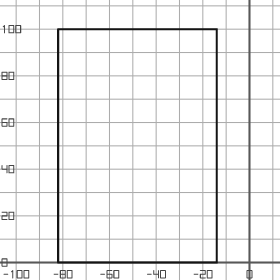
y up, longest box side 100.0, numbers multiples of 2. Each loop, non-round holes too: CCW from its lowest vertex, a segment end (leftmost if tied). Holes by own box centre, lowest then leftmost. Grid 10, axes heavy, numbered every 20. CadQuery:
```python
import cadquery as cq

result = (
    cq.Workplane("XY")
    .moveTo(-82.0, 0.0)
    .lineTo(-14.0, 0.0)
    .lineTo(-14.0, 100.0)
    .lineTo(-82.0, 100.0)
    .close()
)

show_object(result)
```